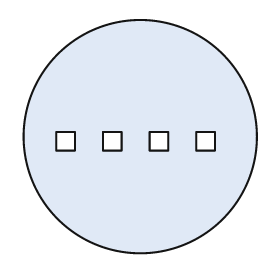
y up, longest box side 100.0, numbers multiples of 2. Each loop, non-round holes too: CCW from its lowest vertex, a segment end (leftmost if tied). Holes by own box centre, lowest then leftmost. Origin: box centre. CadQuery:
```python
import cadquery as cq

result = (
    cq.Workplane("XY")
    .moveTo(0.0, 0.0)
    .circle(50.0)
    .moveTo(-36.0, -6.0)
    .lineTo(-28.0, -6.0)
    .lineTo(-28.0, 2.0)
    .lineTo(-36.0, 2.0)
    .close()
    .moveTo(-16.0, -6.0)
    .lineTo(-8.0, -6.0)
    .lineTo(-8.0, 2.0)
    .lineTo(-16.0, 2.0)
    .close()
    .moveTo(4.0, -6.0)
    .lineTo(12.0, -6.0)
    .lineTo(12.0, 2.0)
    .lineTo(4.0, 2.0)
    .close()
    .moveTo(24.0, -6.0)
    .lineTo(32.0, -6.0)
    .lineTo(32.0, 2.0)
    .lineTo(24.0, 2.0)
    .close()
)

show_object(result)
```